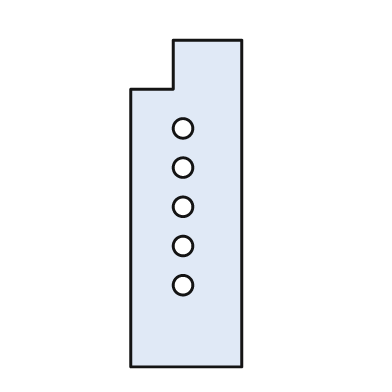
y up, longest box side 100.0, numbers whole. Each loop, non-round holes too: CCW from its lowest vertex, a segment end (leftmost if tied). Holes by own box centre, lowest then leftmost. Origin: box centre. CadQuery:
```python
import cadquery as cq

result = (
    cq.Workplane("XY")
    .moveTo(-17.0, -50.0)
    .lineTo(17.0, -50.0)
    .lineTo(17.0, 50.0)
    .lineTo(-4.0, 50.0)
    .lineTo(-4.0, 35.0)
    .lineTo(-17.0, 35.0)
    .close()
    .moveTo(-1.0, -25.0)
    .circle(3.0)
    .moveTo(-1.0, -13.0)
    .circle(3.0)
    .moveTo(-1.0, -1.0)
    .circle(3.0)
    .moveTo(-1.0, 11.0)
    .circle(3.0)
    .moveTo(-1.0, 23.0)
    .circle(3.0)
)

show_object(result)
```